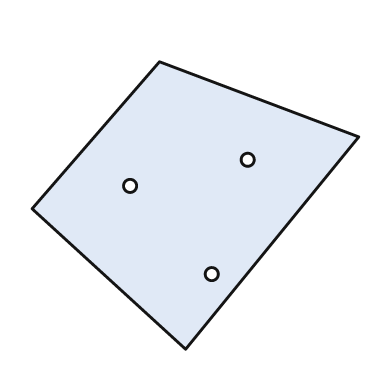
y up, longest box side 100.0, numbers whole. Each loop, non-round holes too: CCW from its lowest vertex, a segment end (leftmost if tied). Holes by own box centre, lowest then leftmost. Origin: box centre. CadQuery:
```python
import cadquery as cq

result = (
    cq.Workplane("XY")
    .moveTo(-3.0, -44.0)
    .lineTo(50.0, 21.0)
    .lineTo(-11.0, 44.0)
    .lineTo(-50.0, -1.0)
    .close()
    .moveTo(5.0, -21.0)
    .circle(2.0)
    .moveTo(-20.0, 6.0)
    .circle(2.0)
    .moveTo(16.0, 14.0)
    .circle(2.0)
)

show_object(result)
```